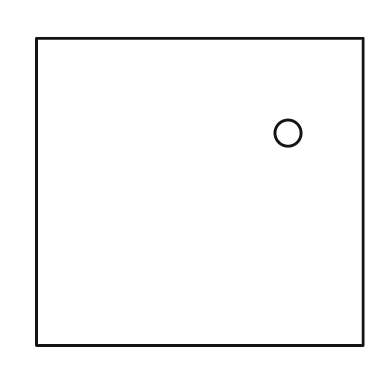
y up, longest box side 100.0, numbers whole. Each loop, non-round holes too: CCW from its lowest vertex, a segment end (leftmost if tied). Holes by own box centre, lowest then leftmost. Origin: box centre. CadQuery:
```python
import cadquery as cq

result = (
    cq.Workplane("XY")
    .moveTo(-50.0, -47.0)
    .lineTo(50.0, -47.0)
    .lineTo(50.0, 47.0)
    .lineTo(-50.0, 47.0)
    .close()
    .moveTo(27.0, 18.0)
    .circle(4.0)
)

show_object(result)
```